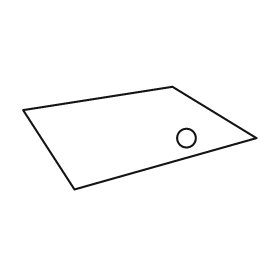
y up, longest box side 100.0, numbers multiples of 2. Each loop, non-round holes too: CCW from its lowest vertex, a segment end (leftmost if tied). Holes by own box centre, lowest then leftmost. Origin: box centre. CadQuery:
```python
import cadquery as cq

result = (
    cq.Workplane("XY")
    .moveTo(-28.0, -22.0)
    .lineTo(50.0, 0.0)
    .lineTo(14.0, 22.0)
    .lineTo(-50.0, 12.0)
    .close()
    .moveTo(20.0, 0.0)
    .circle(4.0)
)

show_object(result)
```